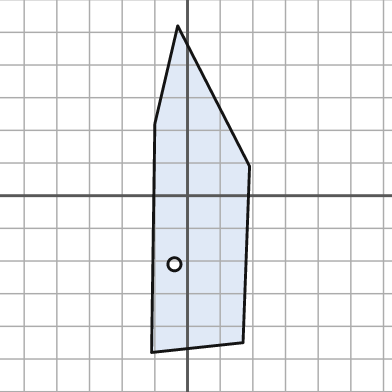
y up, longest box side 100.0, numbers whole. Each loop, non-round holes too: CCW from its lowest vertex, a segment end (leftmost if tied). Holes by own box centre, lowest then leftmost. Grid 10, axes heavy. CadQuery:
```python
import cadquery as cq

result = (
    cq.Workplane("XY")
    .moveTo(-11.0, -48.0)
    .lineTo(17.0, -45.0)
    .lineTo(19.0, 9.0)
    .lineTo(-3.0, 52.0)
    .lineTo(-10.0, 22.0)
    .close()
    .moveTo(-4.0, -21.0)
    .circle(2.0)
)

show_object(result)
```